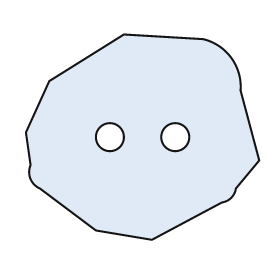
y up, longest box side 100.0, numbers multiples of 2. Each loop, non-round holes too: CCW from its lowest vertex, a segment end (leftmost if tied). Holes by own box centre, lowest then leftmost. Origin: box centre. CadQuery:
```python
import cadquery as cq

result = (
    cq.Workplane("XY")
    .moveTo(4.0, -44.0)
    .lineTo(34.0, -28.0)
    .threePointArc((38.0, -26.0), (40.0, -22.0))
    .lineTo(50.0, -10.0)
    .lineTo(42.0, 20.0)
    .threePointArc((38.0, 34.0), (26.0, 42.0))
    .lineTo(-8.0, 44.0)
    .lineTo(-40.0, 24.0)
    .lineTo(-50.0, 2.0)
    .lineTo(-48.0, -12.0)
    .threePointArc((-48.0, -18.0), (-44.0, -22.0))
    .lineTo(-20.0, -40.0)
    .close()
    .moveTo(-14.0, 0.0)
    .circle(6.0)
    .moveTo(14.0, 0.0)
    .circle(6.0)
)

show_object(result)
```